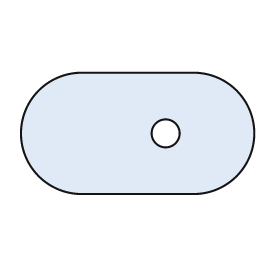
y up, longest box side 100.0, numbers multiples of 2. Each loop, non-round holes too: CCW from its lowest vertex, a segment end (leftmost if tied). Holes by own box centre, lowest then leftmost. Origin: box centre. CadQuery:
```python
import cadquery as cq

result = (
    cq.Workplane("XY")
    .moveTo(-24.0, -26.0)
    .lineTo(24.0, -26.0)
    .threePointArc((50.0, 0.0), (24.0, 26.0))
    .lineTo(-24.0, 26.0)
    .threePointArc((-50.0, 0.0), (-24.0, -26.0))
    .close()
    .moveTo(12.0, 0.0)
    .circle(6.0)
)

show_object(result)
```